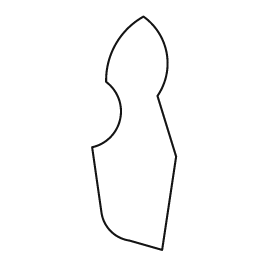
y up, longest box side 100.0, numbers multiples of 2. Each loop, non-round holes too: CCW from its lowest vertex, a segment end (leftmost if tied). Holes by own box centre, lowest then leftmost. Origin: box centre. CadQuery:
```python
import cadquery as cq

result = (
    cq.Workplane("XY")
    .moveTo(12.0, -50.0)
    .lineTo(18.0, -10.0)
    .lineTo(10.0, 16.0)
    .threePointArc((14.0, 34.0), (4.0, 50.0))
    .threePointArc((-8.0, 38.0), (-12.0, 22.0))
    .threePointArc((-6.0, 6.0), (-18.0, -6.0))
    .lineTo(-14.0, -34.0)
    .threePointArc((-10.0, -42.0), (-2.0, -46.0))
    .close()
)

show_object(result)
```